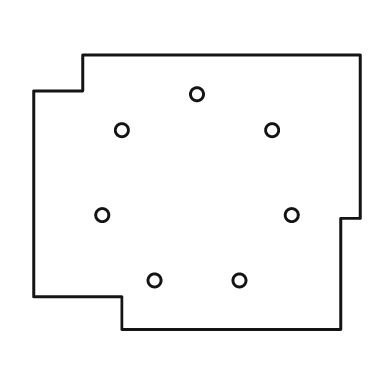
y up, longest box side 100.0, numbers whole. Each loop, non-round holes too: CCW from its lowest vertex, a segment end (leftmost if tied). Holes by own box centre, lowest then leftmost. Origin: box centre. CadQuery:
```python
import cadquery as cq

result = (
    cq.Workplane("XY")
    .moveTo(-23.0, -42.0)
    .lineTo(44.0, -42.0)
    .lineTo(44.0, -8.0)
    .lineTo(50.0, -8.0)
    .lineTo(50.0, 42.0)
    .lineTo(-35.0, 42.0)
    .lineTo(-35.0, 31.0)
    .lineTo(-50.0, 31.0)
    .lineTo(-50.0, -32.0)
    .lineTo(-23.0, -32.0)
    .close()
    .moveTo(-13.0, -27.0)
    .circle(2.0)
    .moveTo(13.0, -27.0)
    .circle(2.0)
    .moveTo(-29.0, -7.0)
    .circle(2.0)
    .moveTo(29.0, -7.0)
    .circle(2.0)
    .moveTo(-23.0, 19.0)
    .circle(2.0)
    .moveTo(23.0, 19.0)
    .circle(2.0)
    .moveTo(0.0, 30.0)
    .circle(2.0)
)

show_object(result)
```